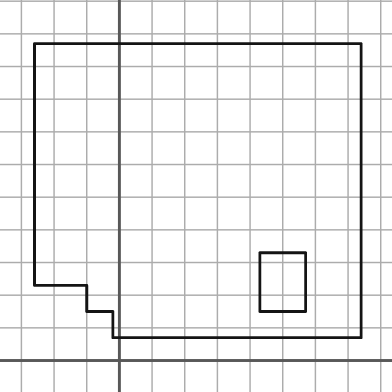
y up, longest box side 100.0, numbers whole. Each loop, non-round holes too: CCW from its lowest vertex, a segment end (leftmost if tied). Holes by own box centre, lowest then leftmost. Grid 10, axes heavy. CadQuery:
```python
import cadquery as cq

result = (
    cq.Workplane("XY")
    .moveTo(-2.0, 7.0)
    .lineTo(74.0, 7.0)
    .lineTo(74.0, 97.0)
    .lineTo(-26.0, 97.0)
    .lineTo(-26.0, 23.0)
    .lineTo(-10.0, 23.0)
    .lineTo(-10.0, 15.0)
    .lineTo(-2.0, 15.0)
    .close()
    .moveTo(43.0, 15.0)
    .lineTo(57.0, 15.0)
    .lineTo(57.0, 33.0)
    .lineTo(43.0, 33.0)
    .close()
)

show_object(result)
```